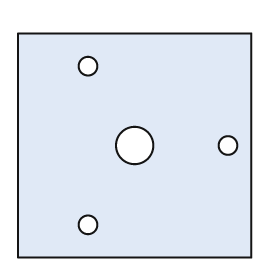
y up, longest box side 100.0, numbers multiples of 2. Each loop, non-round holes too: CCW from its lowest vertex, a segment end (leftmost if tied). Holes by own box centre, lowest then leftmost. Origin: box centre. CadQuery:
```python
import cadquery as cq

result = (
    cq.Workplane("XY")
    .moveTo(-50.0, -48.0)
    .lineTo(50.0, -48.0)
    .lineTo(50.0, 48.0)
    .lineTo(-50.0, 48.0)
    .close()
    .moveTo(-20.0, -34.0)
    .circle(4.0)
    .moveTo(0.0, 0.0)
    .circle(8.0)
    .moveTo(40.0, 0.0)
    .circle(4.0)
    .moveTo(-20.0, 34.0)
    .circle(4.0)
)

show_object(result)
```